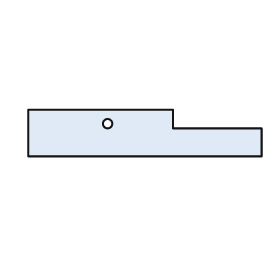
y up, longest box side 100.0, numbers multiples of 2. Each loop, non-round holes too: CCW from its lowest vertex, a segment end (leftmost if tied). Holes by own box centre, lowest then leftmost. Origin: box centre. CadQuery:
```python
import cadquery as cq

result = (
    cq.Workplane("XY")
    .moveTo(-50.0, -10.0)
    .lineTo(50.0, -10.0)
    .lineTo(50.0, 2.0)
    .lineTo(12.0, 2.0)
    .lineTo(12.0, 10.0)
    .lineTo(-50.0, 10.0)
    .close()
    .moveTo(-16.0, 4.0)
    .circle(2.0)
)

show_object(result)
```